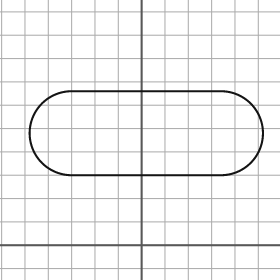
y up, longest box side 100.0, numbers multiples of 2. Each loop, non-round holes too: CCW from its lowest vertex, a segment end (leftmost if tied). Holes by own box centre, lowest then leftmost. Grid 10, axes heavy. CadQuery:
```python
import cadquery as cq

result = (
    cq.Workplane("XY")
    .moveTo(-30.0, 30.0)
    .lineTo(34.0, 30.0)
    .threePointArc((52.0, 48.0), (34.0, 66.0))
    .lineTo(-30.0, 66.0)
    .threePointArc((-48.0, 48.0), (-30.0, 30.0))
    .close()
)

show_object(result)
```